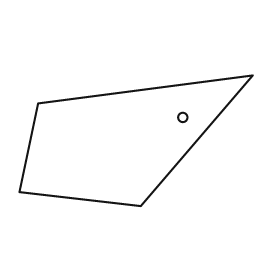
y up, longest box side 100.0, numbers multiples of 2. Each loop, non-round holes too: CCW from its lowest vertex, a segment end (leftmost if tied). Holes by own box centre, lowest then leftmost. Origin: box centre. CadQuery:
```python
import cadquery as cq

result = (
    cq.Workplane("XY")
    .moveTo(2.0, -28.0)
    .lineTo(50.0, 28.0)
    .lineTo(-42.0, 16.0)
    .lineTo(-50.0, -22.0)
    .close()
    .moveTo(20.0, 10.0)
    .circle(2.0)
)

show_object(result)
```